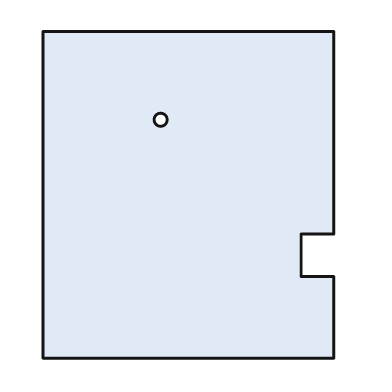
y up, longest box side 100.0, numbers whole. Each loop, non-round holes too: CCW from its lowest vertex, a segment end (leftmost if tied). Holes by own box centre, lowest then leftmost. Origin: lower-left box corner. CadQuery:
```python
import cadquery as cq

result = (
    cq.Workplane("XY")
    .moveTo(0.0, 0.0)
    .lineTo(89.0, 0.0)
    .lineTo(89.0, 25.0)
    .lineTo(79.0, 25.0)
    .lineTo(79.0, 38.0)
    .lineTo(89.0, 38.0)
    .lineTo(89.0, 100.0)
    .lineTo(0.0, 100.0)
    .close()
    .moveTo(36.0, 73.0)
    .circle(2.0)
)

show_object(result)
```